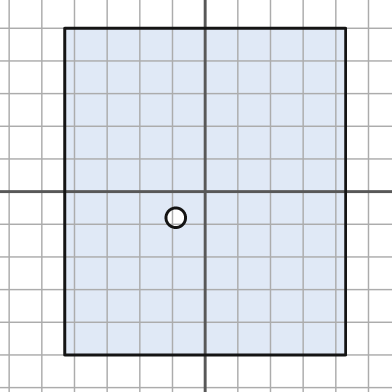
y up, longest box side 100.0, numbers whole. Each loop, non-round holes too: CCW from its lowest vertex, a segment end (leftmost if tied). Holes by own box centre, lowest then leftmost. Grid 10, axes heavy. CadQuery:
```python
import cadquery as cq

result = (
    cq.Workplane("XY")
    .moveTo(-43.0, -50.0)
    .lineTo(43.0, -50.0)
    .lineTo(43.0, 50.0)
    .lineTo(-43.0, 50.0)
    .close()
    .moveTo(-9.0, -8.0)
    .circle(3.0)
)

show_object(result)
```